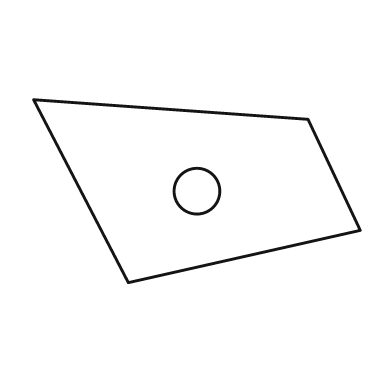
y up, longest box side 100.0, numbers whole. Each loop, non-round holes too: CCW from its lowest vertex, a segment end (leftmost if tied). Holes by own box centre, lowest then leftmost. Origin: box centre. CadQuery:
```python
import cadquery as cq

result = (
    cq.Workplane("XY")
    .moveTo(-21.0, -28.0)
    .lineTo(50.0, -12.0)
    .lineTo(34.0, 22.0)
    .lineTo(-50.0, 28.0)
    .close()
    .moveTo(0.0, 0.0)
    .circle(7.0)
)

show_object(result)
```